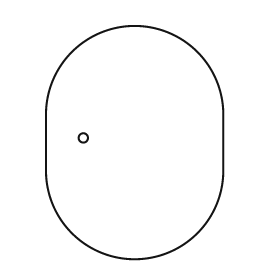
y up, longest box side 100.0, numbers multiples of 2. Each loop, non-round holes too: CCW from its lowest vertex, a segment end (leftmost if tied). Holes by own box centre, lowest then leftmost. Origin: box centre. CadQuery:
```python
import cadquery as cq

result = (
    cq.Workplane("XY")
    .moveTo(-38.0, -12.0)
    .threePointArc((0.0, -50.0), (38.0, -12.0))
    .lineTo(38.0, 12.0)
    .threePointArc((0.0, 50.0), (-38.0, 12.0))
    .close()
    .moveTo(-22.0, 2.0)
    .circle(2.0)
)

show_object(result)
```